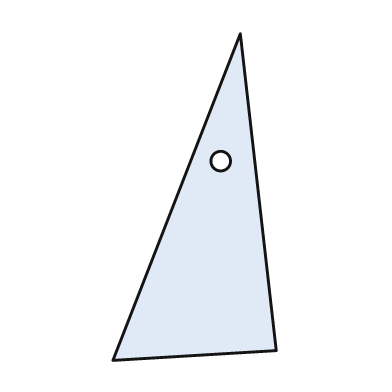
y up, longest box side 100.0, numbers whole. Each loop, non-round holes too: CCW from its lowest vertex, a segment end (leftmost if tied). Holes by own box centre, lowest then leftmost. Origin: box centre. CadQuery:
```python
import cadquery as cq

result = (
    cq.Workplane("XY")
    .moveTo(-25.0, -50.0)
    .lineTo(25.0, -47.0)
    .lineTo(14.0, 50.0)
    .close()
    .moveTo(8.0, 11.0)
    .circle(3.0)
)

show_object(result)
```